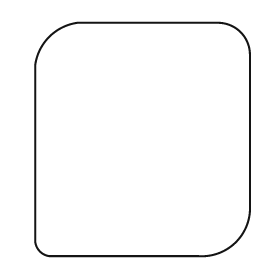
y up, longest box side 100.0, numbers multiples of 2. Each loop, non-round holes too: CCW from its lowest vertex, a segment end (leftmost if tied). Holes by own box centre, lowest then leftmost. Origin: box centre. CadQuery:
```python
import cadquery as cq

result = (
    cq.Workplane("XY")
    .moveTo(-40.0, -50.0)
    .lineTo(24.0, -50.0)
    .threePointArc((40.0, -44.0), (46.0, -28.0))
    .lineTo(46.0, 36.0)
    .threePointArc((42.0, 46.0), (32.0, 50.0))
    .lineTo(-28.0, 50.0)
    .threePointArc((-40.0, 44.0), (-46.0, 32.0))
    .lineTo(-46.0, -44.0)
    .threePointArc((-44.0, -48.0), (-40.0, -50.0))
    .close()
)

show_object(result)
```